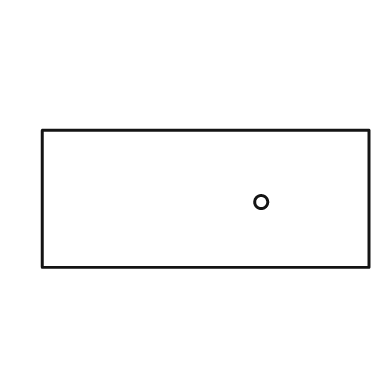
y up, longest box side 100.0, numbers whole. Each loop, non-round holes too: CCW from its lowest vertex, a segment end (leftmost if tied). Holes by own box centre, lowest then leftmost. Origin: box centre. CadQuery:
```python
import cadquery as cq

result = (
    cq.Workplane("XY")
    .moveTo(-50.0, -21.0)
    .lineTo(50.0, -21.0)
    .lineTo(50.0, 21.0)
    .lineTo(-50.0, 21.0)
    .close()
    .moveTo(17.0, -1.0)
    .circle(2.0)
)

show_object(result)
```